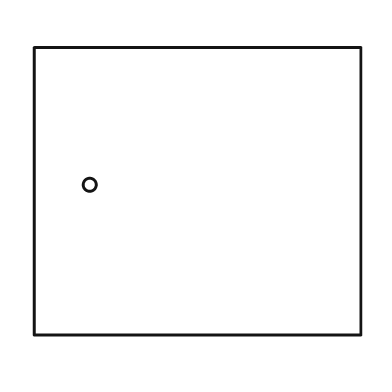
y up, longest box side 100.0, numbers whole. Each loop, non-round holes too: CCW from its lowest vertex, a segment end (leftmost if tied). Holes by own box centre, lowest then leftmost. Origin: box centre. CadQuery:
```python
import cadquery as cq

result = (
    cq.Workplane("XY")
    .moveTo(-50.0, -44.0)
    .lineTo(50.0, -44.0)
    .lineTo(50.0, 44.0)
    .lineTo(-50.0, 44.0)
    .close()
    .moveTo(-33.0, 2.0)
    .circle(2.0)
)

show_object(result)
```